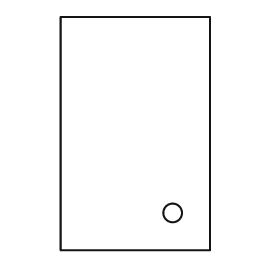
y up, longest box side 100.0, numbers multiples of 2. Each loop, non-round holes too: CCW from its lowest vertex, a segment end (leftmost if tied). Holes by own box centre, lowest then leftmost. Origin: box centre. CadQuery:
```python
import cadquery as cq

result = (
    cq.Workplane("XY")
    .moveTo(-32.0, -50.0)
    .lineTo(32.0, -50.0)
    .lineTo(32.0, 50.0)
    .lineTo(-32.0, 50.0)
    .close()
    .moveTo(16.0, -34.0)
    .circle(4.0)
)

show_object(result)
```